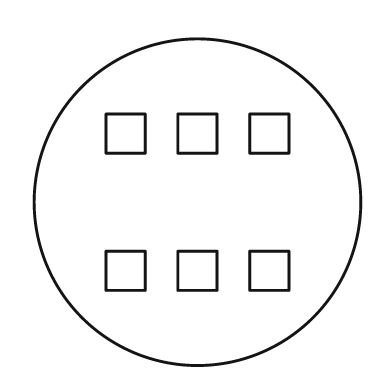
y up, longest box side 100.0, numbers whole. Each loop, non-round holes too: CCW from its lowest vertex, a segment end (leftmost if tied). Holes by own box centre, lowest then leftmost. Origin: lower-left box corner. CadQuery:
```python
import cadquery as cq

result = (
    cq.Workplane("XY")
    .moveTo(50.0, 50.0)
    .circle(50.0)
    .moveTo(22.0, 23.0)
    .lineTo(34.0, 23.0)
    .lineTo(34.0, 35.0)
    .lineTo(22.0, 35.0)
    .close()
    .moveTo(44.0, 23.0)
    .lineTo(56.0, 23.0)
    .lineTo(56.0, 35.0)
    .lineTo(44.0, 35.0)
    .close()
    .moveTo(66.0, 23.0)
    .lineTo(78.0, 23.0)
    .lineTo(78.0, 35.0)
    .lineTo(66.0, 35.0)
    .close()
    .moveTo(22.0, 65.0)
    .lineTo(34.0, 65.0)
    .lineTo(34.0, 77.0)
    .lineTo(22.0, 77.0)
    .close()
    .moveTo(44.0, 65.0)
    .lineTo(56.0, 65.0)
    .lineTo(56.0, 77.0)
    .lineTo(44.0, 77.0)
    .close()
    .moveTo(66.0, 65.0)
    .lineTo(78.0, 65.0)
    .lineTo(78.0, 77.0)
    .lineTo(66.0, 77.0)
    .close()
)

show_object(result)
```